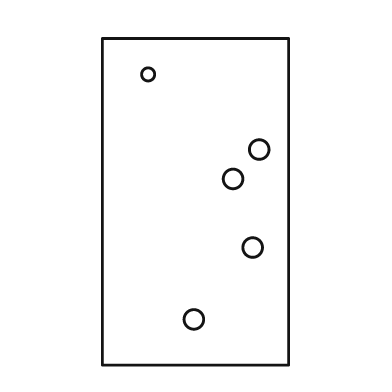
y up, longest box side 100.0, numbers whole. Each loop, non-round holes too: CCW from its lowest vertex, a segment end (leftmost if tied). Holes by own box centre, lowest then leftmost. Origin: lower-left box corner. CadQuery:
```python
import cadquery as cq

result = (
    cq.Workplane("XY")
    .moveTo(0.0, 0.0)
    .lineTo(57.0, 0.0)
    .lineTo(57.0, 100.0)
    .lineTo(0.0, 100.0)
    .close()
    .moveTo(28.0, 14.0)
    .circle(3.0)
    .moveTo(46.0, 36.0)
    .circle(3.0)
    .moveTo(40.0, 57.0)
    .circle(3.0)
    .moveTo(48.0, 66.0)
    .circle(3.0)
    .moveTo(14.0, 89.0)
    .circle(2.0)
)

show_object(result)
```